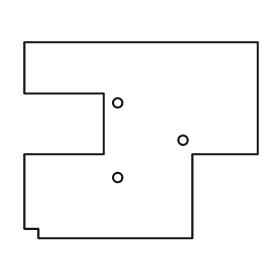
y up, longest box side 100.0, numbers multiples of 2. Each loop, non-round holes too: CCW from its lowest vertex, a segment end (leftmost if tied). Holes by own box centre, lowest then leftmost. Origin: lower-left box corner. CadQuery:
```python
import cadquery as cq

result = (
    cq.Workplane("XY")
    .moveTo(6.0, 0.0)
    .lineTo(72.0, 0.0)
    .lineTo(72.0, 36.0)
    .lineTo(100.0, 36.0)
    .lineTo(100.0, 84.0)
    .lineTo(0.0, 84.0)
    .lineTo(0.0, 62.0)
    .lineTo(34.0, 62.0)
    .lineTo(34.0, 36.0)
    .lineTo(0.0, 36.0)
    .lineTo(0.0, 4.0)
    .lineTo(6.0, 4.0)
    .close()
    .moveTo(40.0, 26.0)
    .circle(2.0)
    .moveTo(68.0, 42.0)
    .circle(2.0)
    .moveTo(40.0, 58.0)
    .circle(2.0)
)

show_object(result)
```